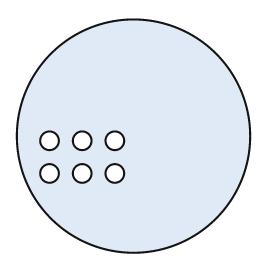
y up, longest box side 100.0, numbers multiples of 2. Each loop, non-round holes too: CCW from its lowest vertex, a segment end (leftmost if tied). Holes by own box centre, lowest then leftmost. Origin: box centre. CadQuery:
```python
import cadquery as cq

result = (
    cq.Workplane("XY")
    .moveTo(0.0, 0.0)
    .circle(50.0)
    .moveTo(-36.0, -16.0)
    .circle(4.0)
    .moveTo(-22.0, -16.0)
    .circle(4.0)
    .moveTo(-8.0, -16.0)
    .circle(4.0)
    .moveTo(-36.0, -2.0)
    .circle(4.0)
    .moveTo(-22.0, -2.0)
    .circle(4.0)
    .moveTo(-8.0, -2.0)
    .circle(4.0)
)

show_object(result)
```